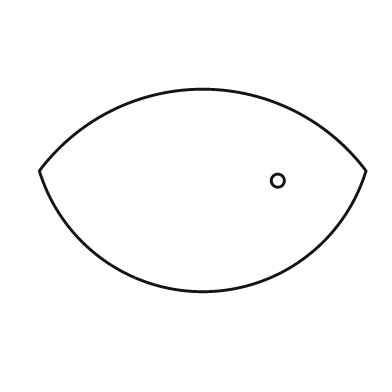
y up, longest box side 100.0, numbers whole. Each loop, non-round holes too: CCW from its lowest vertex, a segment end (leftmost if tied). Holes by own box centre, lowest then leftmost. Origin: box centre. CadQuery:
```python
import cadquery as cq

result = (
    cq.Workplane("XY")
    .moveTo(-50.0, 6.0)
    .threePointArc((0.0, -31.0), (50.0, 6.0))
    .threePointArc((0.0, 31.0), (-50.0, 6.0))
    .close()
    .moveTo(23.0, 3.0)
    .circle(2.0)
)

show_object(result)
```